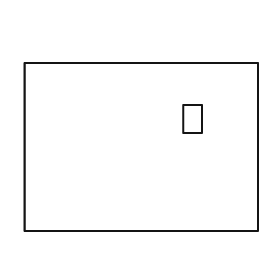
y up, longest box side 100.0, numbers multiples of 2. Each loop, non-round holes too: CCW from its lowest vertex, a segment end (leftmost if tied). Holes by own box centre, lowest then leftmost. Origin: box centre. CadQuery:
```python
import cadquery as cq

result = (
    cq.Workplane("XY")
    .moveTo(-50.0, -36.0)
    .lineTo(50.0, -36.0)
    .lineTo(50.0, 36.0)
    .lineTo(-50.0, 36.0)
    .close()
    .moveTo(18.0, 6.0)
    .lineTo(26.0, 6.0)
    .lineTo(26.0, 18.0)
    .lineTo(18.0, 18.0)
    .close()
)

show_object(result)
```